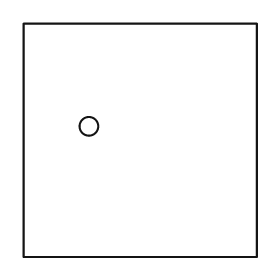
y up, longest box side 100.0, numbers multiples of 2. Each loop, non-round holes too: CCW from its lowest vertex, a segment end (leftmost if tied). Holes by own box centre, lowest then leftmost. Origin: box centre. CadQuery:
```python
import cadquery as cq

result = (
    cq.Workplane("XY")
    .moveTo(-50.0, -50.0)
    .lineTo(50.0, -50.0)
    .lineTo(50.0, 50.0)
    .lineTo(-50.0, 50.0)
    .close()
    .moveTo(-22.0, 6.0)
    .circle(4.0)
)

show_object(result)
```